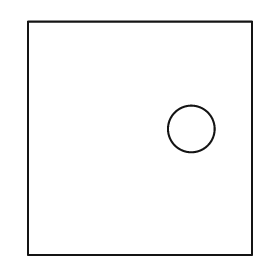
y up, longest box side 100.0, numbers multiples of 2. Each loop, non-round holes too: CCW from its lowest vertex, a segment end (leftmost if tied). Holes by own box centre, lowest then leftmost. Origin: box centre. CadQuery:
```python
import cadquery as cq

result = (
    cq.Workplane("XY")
    .moveTo(-48.0, -50.0)
    .lineTo(48.0, -50.0)
    .lineTo(48.0, 50.0)
    .lineTo(-48.0, 50.0)
    .close()
    .moveTo(22.0, 4.0)
    .circle(10.0)
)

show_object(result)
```